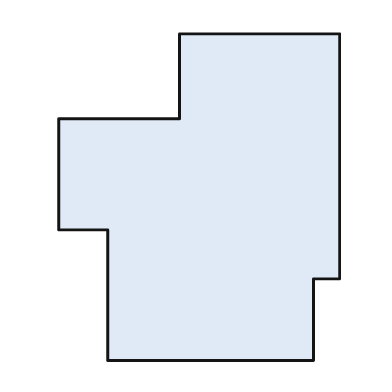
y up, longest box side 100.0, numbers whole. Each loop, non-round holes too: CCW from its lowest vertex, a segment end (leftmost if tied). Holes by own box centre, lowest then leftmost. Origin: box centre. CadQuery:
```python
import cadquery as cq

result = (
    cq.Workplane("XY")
    .moveTo(-28.0, -50.0)
    .lineTo(35.0, -50.0)
    .lineTo(35.0, -25.0)
    .lineTo(43.0, -25.0)
    .lineTo(43.0, 50.0)
    .lineTo(-6.0, 50.0)
    .lineTo(-6.0, 24.0)
    .lineTo(-43.0, 24.0)
    .lineTo(-43.0, -10.0)
    .lineTo(-28.0, -10.0)
    .close()
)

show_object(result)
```